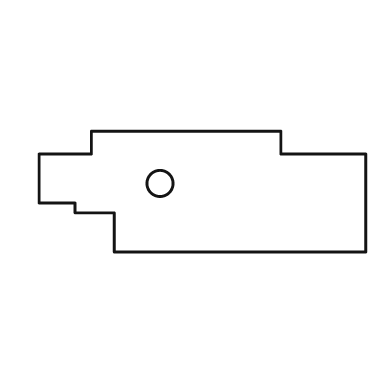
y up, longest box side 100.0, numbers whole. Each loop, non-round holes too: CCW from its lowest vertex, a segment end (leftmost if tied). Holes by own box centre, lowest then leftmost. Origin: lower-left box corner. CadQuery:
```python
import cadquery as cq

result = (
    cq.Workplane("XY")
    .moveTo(23.0, 0.0)
    .lineTo(100.0, 0.0)
    .lineTo(100.0, 30.0)
    .lineTo(74.0, 30.0)
    .lineTo(74.0, 37.0)
    .lineTo(16.0, 37.0)
    .lineTo(16.0, 30.0)
    .lineTo(0.0, 30.0)
    .lineTo(0.0, 15.0)
    .lineTo(11.0, 15.0)
    .lineTo(11.0, 12.0)
    .lineTo(23.0, 12.0)
    .close()
    .moveTo(37.0, 21.0)
    .circle(4.0)
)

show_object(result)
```